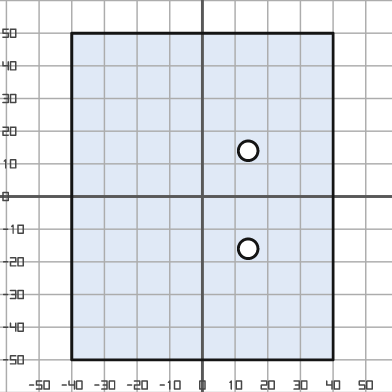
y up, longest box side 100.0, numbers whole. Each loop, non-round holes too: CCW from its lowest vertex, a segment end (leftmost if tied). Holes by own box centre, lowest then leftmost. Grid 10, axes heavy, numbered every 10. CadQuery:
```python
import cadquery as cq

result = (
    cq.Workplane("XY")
    .moveTo(-40.0, -50.0)
    .lineTo(40.0, -50.0)
    .lineTo(40.0, 50.0)
    .lineTo(-40.0, 50.0)
    .close()
    .moveTo(14.0, -16.0)
    .circle(3.0)
    .moveTo(14.0, 14.0)
    .circle(3.0)
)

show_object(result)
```